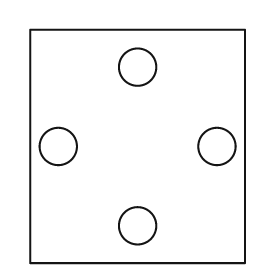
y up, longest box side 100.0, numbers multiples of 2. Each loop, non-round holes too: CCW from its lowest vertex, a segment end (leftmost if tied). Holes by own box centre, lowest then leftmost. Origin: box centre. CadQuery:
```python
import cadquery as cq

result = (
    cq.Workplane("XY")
    .moveTo(-46.0, -50.0)
    .lineTo(46.0, -50.0)
    .lineTo(46.0, 50.0)
    .lineTo(-46.0, 50.0)
    .close()
    .moveTo(0.0, -34.0)
    .circle(8.0)
    .moveTo(-34.0, 0.0)
    .circle(8.0)
    .moveTo(34.0, 0.0)
    .circle(8.0)
    .moveTo(0.0, 34.0)
    .circle(8.0)
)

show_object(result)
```